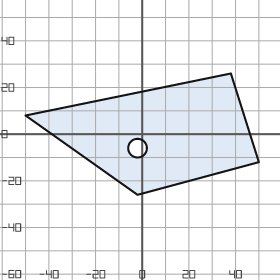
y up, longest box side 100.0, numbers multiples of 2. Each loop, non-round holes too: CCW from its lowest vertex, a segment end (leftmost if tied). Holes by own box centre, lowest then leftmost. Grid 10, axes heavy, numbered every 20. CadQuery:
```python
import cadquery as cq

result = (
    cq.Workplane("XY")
    .moveTo(-2.0, -26.0)
    .lineTo(50.0, -12.0)
    .lineTo(38.0, 26.0)
    .lineTo(-50.0, 8.0)
    .close()
    .moveTo(-2.0, -6.0)
    .circle(4.0)
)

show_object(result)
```